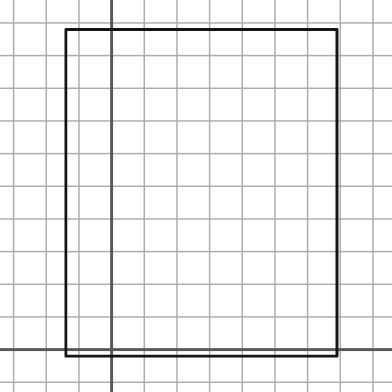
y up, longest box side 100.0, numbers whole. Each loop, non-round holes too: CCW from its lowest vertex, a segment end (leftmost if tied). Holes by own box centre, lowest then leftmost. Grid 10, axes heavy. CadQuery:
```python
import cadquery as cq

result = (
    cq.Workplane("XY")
    .moveTo(-14.0, -2.0)
    .lineTo(69.0, -2.0)
    .lineTo(69.0, 98.0)
    .lineTo(-14.0, 98.0)
    .close()
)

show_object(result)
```